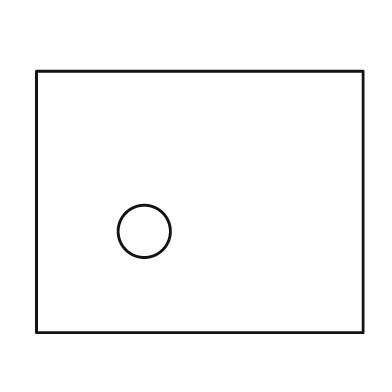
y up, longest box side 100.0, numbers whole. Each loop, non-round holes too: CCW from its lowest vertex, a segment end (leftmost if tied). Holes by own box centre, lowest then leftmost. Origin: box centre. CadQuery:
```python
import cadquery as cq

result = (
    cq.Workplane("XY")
    .moveTo(-50.0, -40.0)
    .lineTo(50.0, -40.0)
    .lineTo(50.0, 40.0)
    .lineTo(-50.0, 40.0)
    .close()
    .moveTo(-17.0, -9.0)
    .circle(8.0)
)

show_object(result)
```